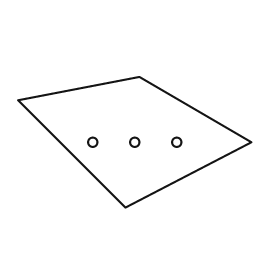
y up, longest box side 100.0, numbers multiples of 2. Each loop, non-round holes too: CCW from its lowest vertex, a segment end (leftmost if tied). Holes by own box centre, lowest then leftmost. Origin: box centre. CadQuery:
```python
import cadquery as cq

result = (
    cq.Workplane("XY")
    .moveTo(-4.0, -28.0)
    .lineTo(50.0, 0.0)
    .lineTo(2.0, 28.0)
    .lineTo(-50.0, 18.0)
    .close()
    .moveTo(-18.0, 0.0)
    .circle(2.0)
    .moveTo(0.0, 0.0)
    .circle(2.0)
    .moveTo(18.0, 0.0)
    .circle(2.0)
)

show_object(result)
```